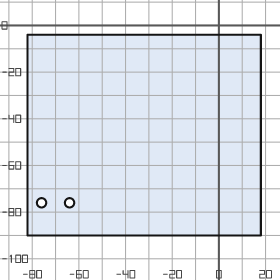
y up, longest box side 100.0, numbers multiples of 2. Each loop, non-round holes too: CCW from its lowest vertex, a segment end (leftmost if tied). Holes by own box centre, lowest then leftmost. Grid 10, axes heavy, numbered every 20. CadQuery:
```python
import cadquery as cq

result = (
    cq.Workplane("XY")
    .moveTo(-82.0, -90.0)
    .lineTo(18.0, -90.0)
    .lineTo(18.0, -4.0)
    .lineTo(-82.0, -4.0)
    .close()
    .moveTo(-76.0, -76.0)
    .circle(2.0)
    .moveTo(-64.0, -76.0)
    .circle(2.0)
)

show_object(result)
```